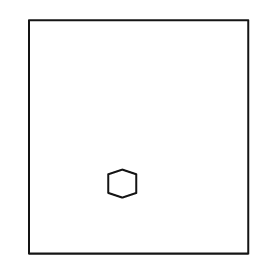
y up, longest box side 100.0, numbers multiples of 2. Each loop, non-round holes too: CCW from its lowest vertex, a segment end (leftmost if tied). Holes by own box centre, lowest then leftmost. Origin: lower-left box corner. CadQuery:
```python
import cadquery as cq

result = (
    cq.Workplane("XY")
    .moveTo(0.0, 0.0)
    .lineTo(94.0, 0.0)
    .lineTo(94.0, 100.0)
    .lineTo(0.0, 100.0)
    .close()
    .moveTo(40.0, 24.0)
    .lineTo(46.0, 26.0)
    .lineTo(46.0, 34.0)
    .lineTo(40.0, 36.0)
    .lineTo(34.0, 34.0)
    .lineTo(34.0, 26.0)
    .close()
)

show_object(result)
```